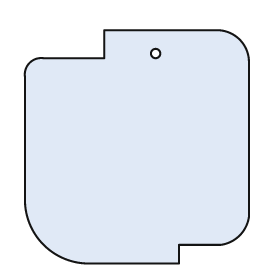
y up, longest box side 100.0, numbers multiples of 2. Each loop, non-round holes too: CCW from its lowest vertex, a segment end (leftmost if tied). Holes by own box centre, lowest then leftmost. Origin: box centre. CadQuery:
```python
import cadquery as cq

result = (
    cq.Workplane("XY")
    .moveTo(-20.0, -50.0)
    .lineTo(18.0, -50.0)
    .lineTo(18.0, -42.0)
    .lineTo(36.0, -42.0)
    .threePointArc((44.0, -38.0), (48.0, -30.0))
    .lineTo(48.0, 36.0)
    .threePointArc((44.0, 46.0), (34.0, 50.0))
    .lineTo(-14.0, 50.0)
    .lineTo(-14.0, 38.0)
    .lineTo(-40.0, 38.0)
    .threePointArc((-46.0, 36.0), (-48.0, 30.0))
    .lineTo(-48.0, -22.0)
    .threePointArc((-40.0, -42.0), (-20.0, -50.0))
    .close()
    .moveTo(8.0, 40.0)
    .circle(2.0)
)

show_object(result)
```